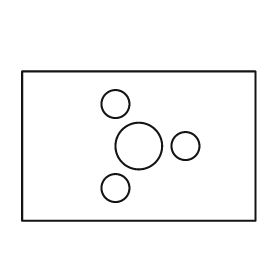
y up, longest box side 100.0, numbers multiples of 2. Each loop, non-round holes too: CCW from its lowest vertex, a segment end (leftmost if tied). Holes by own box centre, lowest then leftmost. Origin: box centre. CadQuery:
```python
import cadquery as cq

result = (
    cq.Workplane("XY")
    .moveTo(-50.0, -32.0)
    .lineTo(50.0, -32.0)
    .lineTo(50.0, 32.0)
    .lineTo(-50.0, 32.0)
    .close()
    .moveTo(-10.0, -18.0)
    .circle(6.0)
    .moveTo(0.0, 0.0)
    .circle(10.0)
    .moveTo(20.0, 0.0)
    .circle(6.0)
    .moveTo(-10.0, 18.0)
    .circle(6.0)
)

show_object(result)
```